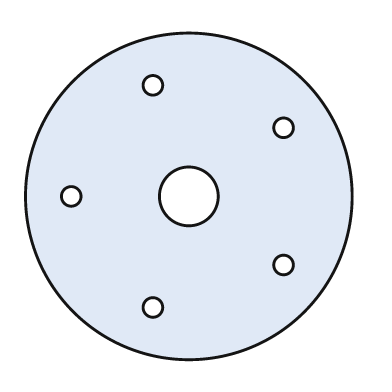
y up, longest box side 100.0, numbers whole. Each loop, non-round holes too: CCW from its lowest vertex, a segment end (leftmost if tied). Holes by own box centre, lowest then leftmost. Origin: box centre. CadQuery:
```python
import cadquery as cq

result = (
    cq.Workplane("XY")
    .moveTo(0.0, 0.0)
    .circle(50.0)
    .moveTo(-11.0, -34.0)
    .circle(3.0)
    .moveTo(29.0, -21.0)
    .circle(3.0)
    .moveTo(-36.0, 0.0)
    .circle(3.0)
    .moveTo(0.0, 0.0)
    .circle(9.0)
    .moveTo(29.0, 21.0)
    .circle(3.0)
    .moveTo(-11.0, 34.0)
    .circle(3.0)
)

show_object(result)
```